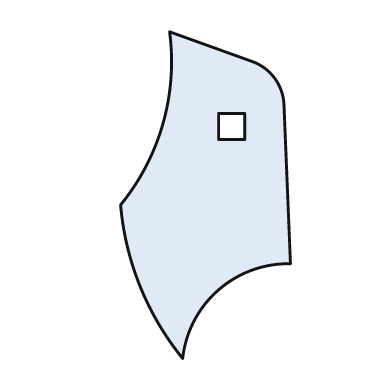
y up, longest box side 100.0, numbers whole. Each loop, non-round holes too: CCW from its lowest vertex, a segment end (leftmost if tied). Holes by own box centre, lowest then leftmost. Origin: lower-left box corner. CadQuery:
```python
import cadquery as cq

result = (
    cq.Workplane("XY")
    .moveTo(19.0, 0.0)
    .threePointArc((30.0, 21.0), (52.0, 29.0))
    .lineTo(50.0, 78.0)
    .threePointArc((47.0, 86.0), (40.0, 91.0))
    .lineTo(15.0, 100.0)
    .threePointArc((13.0, 72.0), (0.0, 47.0))
    .threePointArc((6.0, 22.0), (19.0, 0.0))
    .close()
    .moveTo(30.0, 67.0)
    .lineTo(38.0, 67.0)
    .lineTo(38.0, 75.0)
    .lineTo(30.0, 75.0)
    .close()
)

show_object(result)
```